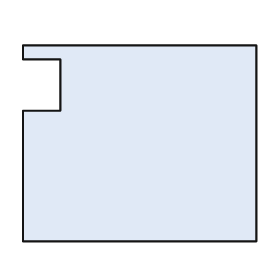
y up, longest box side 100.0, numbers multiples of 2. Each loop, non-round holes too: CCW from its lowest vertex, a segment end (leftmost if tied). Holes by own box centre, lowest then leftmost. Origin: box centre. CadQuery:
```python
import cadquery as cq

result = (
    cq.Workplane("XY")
    .moveTo(-50.0, -42.0)
    .lineTo(50.0, -42.0)
    .lineTo(50.0, 42.0)
    .lineTo(-50.0, 42.0)
    .lineTo(-50.0, 36.0)
    .lineTo(-34.0, 36.0)
    .lineTo(-34.0, 14.0)
    .lineTo(-50.0, 14.0)
    .close()
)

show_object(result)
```